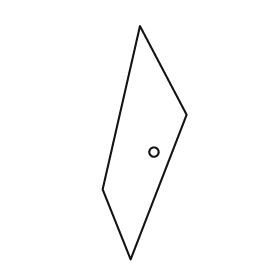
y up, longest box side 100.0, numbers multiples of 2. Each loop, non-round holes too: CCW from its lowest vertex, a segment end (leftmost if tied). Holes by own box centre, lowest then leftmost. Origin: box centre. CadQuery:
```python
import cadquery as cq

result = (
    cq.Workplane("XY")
    .moveTo(-6.0, -50.0)
    .lineTo(18.0, 12.0)
    .lineTo(-2.0, 50.0)
    .lineTo(-18.0, -20.0)
    .close()
    .moveTo(4.0, -4.0)
    .circle(2.0)
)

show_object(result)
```